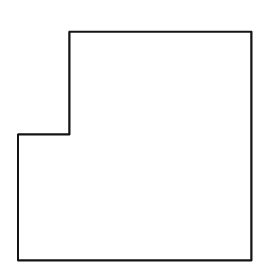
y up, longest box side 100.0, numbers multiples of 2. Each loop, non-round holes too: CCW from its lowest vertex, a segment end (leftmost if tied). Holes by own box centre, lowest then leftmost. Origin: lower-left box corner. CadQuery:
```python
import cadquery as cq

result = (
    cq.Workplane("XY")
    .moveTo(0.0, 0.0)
    .lineTo(100.0, 0.0)
    .lineTo(100.0, 98.0)
    .lineTo(22.0, 98.0)
    .lineTo(22.0, 54.0)
    .lineTo(0.0, 54.0)
    .close()
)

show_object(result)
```